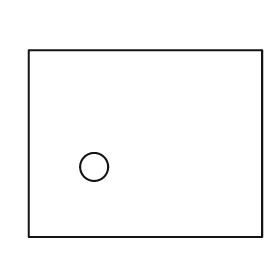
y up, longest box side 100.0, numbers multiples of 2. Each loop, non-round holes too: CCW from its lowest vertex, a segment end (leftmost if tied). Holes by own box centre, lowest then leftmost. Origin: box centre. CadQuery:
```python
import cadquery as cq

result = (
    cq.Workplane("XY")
    .moveTo(-50.0, -40.0)
    .lineTo(50.0, -40.0)
    .lineTo(50.0, 40.0)
    .lineTo(-50.0, 40.0)
    .close()
    .moveTo(-22.0, -10.0)
    .circle(6.0)
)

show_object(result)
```